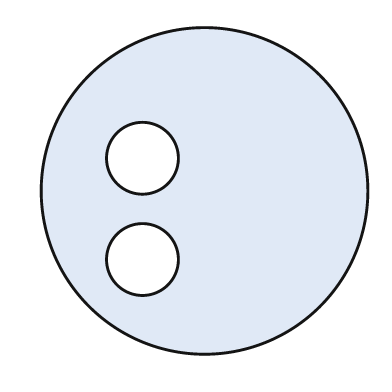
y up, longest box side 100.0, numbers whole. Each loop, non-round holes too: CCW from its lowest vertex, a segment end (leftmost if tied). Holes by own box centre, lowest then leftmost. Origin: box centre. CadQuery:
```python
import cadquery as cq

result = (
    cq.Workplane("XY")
    .moveTo(0.0, 0.0)
    .circle(50.0)
    .moveTo(-19.0, -21.0)
    .circle(11.0)
    .moveTo(-19.0, 10.0)
    .circle(11.0)
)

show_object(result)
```